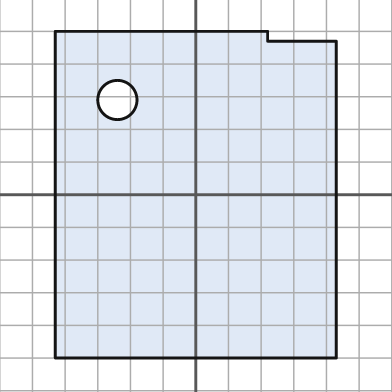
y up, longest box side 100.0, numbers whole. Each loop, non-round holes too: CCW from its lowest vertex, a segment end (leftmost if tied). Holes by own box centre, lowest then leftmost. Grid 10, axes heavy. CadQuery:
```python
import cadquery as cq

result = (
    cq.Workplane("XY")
    .moveTo(-43.0, -50.0)
    .lineTo(43.0, -50.0)
    .lineTo(43.0, 47.0)
    .lineTo(22.0, 47.0)
    .lineTo(22.0, 50.0)
    .lineTo(-43.0, 50.0)
    .close()
    .moveTo(-24.0, 29.0)
    .circle(6.0)
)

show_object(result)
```